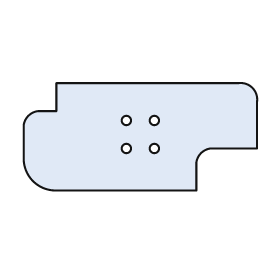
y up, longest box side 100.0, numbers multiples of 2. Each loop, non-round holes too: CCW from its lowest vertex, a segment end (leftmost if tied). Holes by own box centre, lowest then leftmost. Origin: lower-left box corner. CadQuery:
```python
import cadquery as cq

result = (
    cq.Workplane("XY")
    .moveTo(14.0, 0.0)
    .lineTo(74.0, 0.0)
    .lineTo(74.0, 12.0)
    .threePointArc((76.0, 16.0), (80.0, 18.0))
    .lineTo(100.0, 18.0)
    .lineTo(100.0, 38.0)
    .threePointArc((98.0, 44.0), (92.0, 46.0))
    .lineTo(14.0, 46.0)
    .lineTo(14.0, 34.0)
    .lineTo(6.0, 34.0)
    .threePointArc((2.0, 32.0), (0.0, 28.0))
    .lineTo(0.0, 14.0)
    .threePointArc((4.0, 4.0), (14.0, 0.0))
    .close()
    .moveTo(44.0, 18.0)
    .circle(2.0)
    .moveTo(56.0, 18.0)
    .circle(2.0)
    .moveTo(44.0, 30.0)
    .circle(2.0)
    .moveTo(56.0, 30.0)
    .circle(2.0)
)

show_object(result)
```